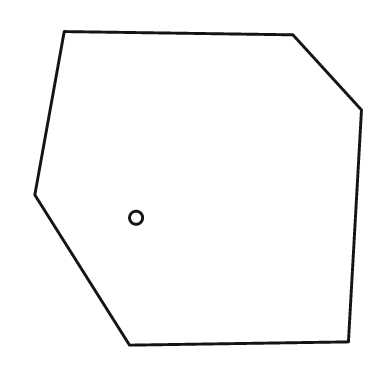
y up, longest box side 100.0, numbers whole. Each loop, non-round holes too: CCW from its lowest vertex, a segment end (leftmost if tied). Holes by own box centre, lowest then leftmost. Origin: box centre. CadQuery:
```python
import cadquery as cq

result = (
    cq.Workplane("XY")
    .moveTo(-21.0, -48.0)
    .lineTo(46.0, -47.0)
    .lineTo(50.0, 24.0)
    .lineTo(29.0, 47.0)
    .lineTo(-41.0, 48.0)
    .lineTo(-50.0, -2.0)
    .close()
    .moveTo(-19.0, -9.0)
    .circle(2.0)
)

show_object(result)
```